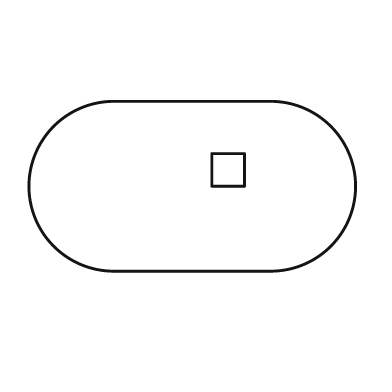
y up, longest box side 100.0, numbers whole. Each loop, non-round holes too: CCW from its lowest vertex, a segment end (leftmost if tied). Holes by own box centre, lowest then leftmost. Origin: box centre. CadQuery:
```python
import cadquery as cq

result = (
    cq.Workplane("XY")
    .moveTo(-24.0, -26.0)
    .lineTo(24.0, -26.0)
    .threePointArc((50.0, 0.0), (24.0, 26.0))
    .lineTo(-24.0, 26.0)
    .threePointArc((-50.0, 0.0), (-24.0, -26.0))
    .close()
    .moveTo(6.0, 0.0)
    .lineTo(16.0, 0.0)
    .lineTo(16.0, 10.0)
    .lineTo(6.0, 10.0)
    .close()
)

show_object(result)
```